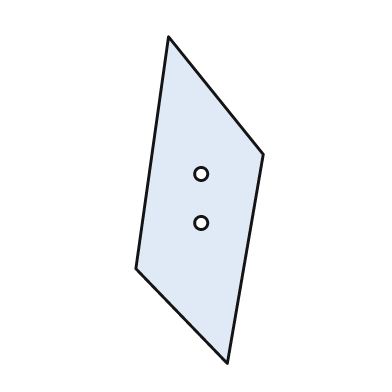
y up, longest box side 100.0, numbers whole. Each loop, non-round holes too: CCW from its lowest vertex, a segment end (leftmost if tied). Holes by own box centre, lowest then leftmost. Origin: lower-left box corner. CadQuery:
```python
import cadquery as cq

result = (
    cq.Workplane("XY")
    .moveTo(28.0, 0.0)
    .lineTo(39.0, 64.0)
    .lineTo(10.0, 100.0)
    .lineTo(0.0, 29.0)
    .close()
    .moveTo(20.0, 43.0)
    .circle(2.0)
    .moveTo(20.0, 58.0)
    .circle(2.0)
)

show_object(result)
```